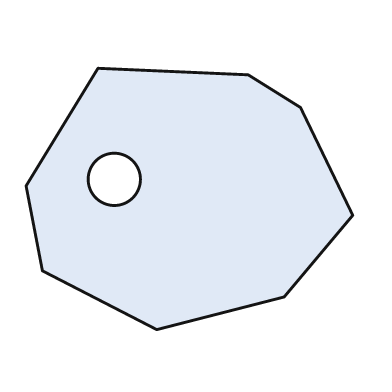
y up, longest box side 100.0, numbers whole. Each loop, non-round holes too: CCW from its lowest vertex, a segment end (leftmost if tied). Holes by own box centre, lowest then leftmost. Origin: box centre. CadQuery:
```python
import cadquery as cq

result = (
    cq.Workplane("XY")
    .moveTo(-10.0, -40.0)
    .lineTo(29.0, -30.0)
    .lineTo(50.0, -5.0)
    .lineTo(34.0, 28.0)
    .lineTo(18.0, 38.0)
    .lineTo(-28.0, 40.0)
    .lineTo(-50.0, 4.0)
    .lineTo(-45.0, -22.0)
    .close()
    .moveTo(-23.0, 6.0)
    .circle(8.0)
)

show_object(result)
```